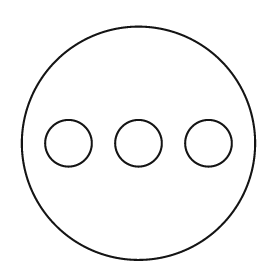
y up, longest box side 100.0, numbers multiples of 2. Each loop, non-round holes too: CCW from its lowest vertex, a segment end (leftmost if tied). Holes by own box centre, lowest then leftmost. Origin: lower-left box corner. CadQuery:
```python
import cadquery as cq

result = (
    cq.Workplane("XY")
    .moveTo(50.0, 50.0)
    .circle(50.0)
    .moveTo(20.0, 50.0)
    .circle(10.0)
    .moveTo(50.0, 50.0)
    .circle(10.0)
    .moveTo(80.0, 50.0)
    .circle(10.0)
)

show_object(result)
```